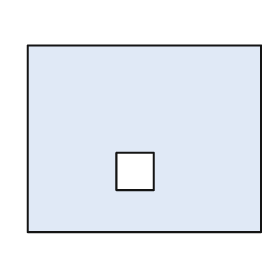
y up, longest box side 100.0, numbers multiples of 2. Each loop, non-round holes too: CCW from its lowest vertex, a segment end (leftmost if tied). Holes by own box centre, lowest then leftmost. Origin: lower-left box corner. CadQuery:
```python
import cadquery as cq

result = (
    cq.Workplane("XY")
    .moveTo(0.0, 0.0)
    .lineTo(100.0, 0.0)
    .lineTo(100.0, 80.0)
    .lineTo(0.0, 80.0)
    .close()
    .moveTo(38.0, 18.0)
    .lineTo(54.0, 18.0)
    .lineTo(54.0, 34.0)
    .lineTo(38.0, 34.0)
    .close()
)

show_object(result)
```